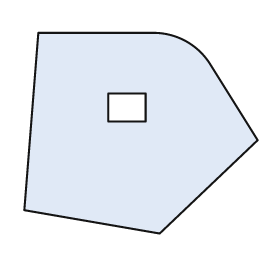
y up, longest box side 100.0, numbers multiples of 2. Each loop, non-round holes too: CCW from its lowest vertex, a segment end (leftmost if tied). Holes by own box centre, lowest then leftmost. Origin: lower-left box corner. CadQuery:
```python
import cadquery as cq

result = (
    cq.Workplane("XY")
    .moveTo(58.0, 0.0)
    .lineTo(100.0, 40.0)
    .lineTo(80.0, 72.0)
    .threePointArc((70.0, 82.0), (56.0, 86.0))
    .lineTo(6.0, 86.0)
    .lineTo(0.0, 10.0)
    .close()
    .moveTo(36.0, 48.0)
    .lineTo(52.0, 48.0)
    .lineTo(52.0, 60.0)
    .lineTo(36.0, 60.0)
    .close()
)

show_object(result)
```